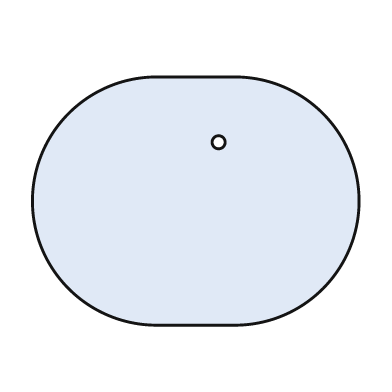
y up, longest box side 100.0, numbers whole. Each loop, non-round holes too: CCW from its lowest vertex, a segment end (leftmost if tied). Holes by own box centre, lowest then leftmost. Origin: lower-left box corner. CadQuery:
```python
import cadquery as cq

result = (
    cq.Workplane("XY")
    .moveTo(38.0, 0.0)
    .lineTo(62.0, 0.0)
    .threePointArc((100.0, 38.0), (62.0, 76.0))
    .lineTo(38.0, 76.0)
    .threePointArc((0.0, 38.0), (38.0, 0.0))
    .close()
    .moveTo(57.0, 56.0)
    .circle(2.0)
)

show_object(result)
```